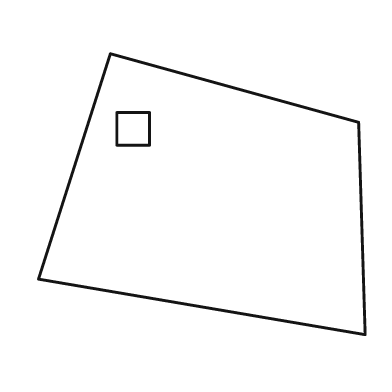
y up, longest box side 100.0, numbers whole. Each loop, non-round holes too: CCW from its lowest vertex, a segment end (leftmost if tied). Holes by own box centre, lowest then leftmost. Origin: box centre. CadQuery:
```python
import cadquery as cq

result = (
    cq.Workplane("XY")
    .moveTo(50.0, -43.0)
    .lineTo(48.0, 22.0)
    .lineTo(-28.0, 43.0)
    .lineTo(-50.0, -26.0)
    .close()
    .moveTo(-26.0, 15.0)
    .lineTo(-16.0, 15.0)
    .lineTo(-16.0, 25.0)
    .lineTo(-26.0, 25.0)
    .close()
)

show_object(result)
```